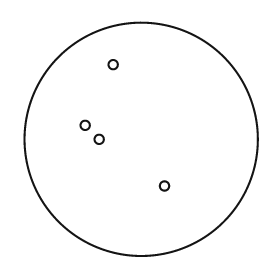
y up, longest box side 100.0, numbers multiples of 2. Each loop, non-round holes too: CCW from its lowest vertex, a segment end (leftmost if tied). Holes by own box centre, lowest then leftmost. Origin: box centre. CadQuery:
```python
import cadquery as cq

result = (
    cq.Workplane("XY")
    .moveTo(0.0, 0.0)
    .circle(50.0)
    .moveTo(10.0, -20.0)
    .circle(2.0)
    .moveTo(-18.0, 0.0)
    .circle(2.0)
    .moveTo(-24.0, 6.0)
    .circle(2.0)
    .moveTo(-12.0, 32.0)
    .circle(2.0)
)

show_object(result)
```